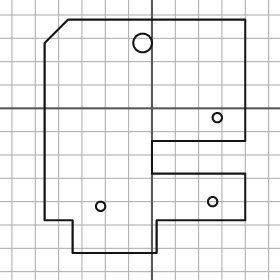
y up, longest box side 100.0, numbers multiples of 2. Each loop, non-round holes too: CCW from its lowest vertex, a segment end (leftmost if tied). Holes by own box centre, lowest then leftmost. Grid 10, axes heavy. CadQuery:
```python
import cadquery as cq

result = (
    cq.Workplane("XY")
    .moveTo(-34.0, -62.0)
    .lineTo(2.0, -62.0)
    .lineTo(2.0, -48.0)
    .lineTo(40.0, -48.0)
    .lineTo(40.0, -28.0)
    .lineTo(0.0, -28.0)
    .lineTo(0.0, -14.0)
    .lineTo(40.0, -14.0)
    .lineTo(40.0, 38.0)
    .lineTo(-36.0, 38.0)
    .lineTo(-46.0, 28.0)
    .lineTo(-46.0, -48.0)
    .lineTo(-34.0, -48.0)
    .close()
    .moveTo(-22.0, -42.0)
    .circle(2.0)
    .moveTo(26.0, -40.0)
    .circle(2.0)
    .moveTo(28.0, -4.0)
    .circle(2.0)
    .moveTo(-4.0, 28.0)
    .circle(4.0)
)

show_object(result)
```